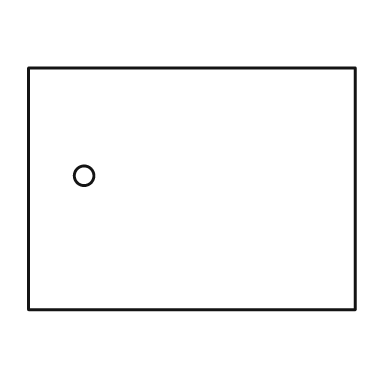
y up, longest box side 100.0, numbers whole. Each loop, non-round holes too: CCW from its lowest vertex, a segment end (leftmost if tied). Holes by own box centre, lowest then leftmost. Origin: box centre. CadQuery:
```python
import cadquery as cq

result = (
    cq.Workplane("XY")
    .moveTo(-50.0, -37.0)
    .lineTo(50.0, -37.0)
    .lineTo(50.0, 37.0)
    .lineTo(-50.0, 37.0)
    .close()
    .moveTo(-33.0, 4.0)
    .circle(3.0)
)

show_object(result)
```